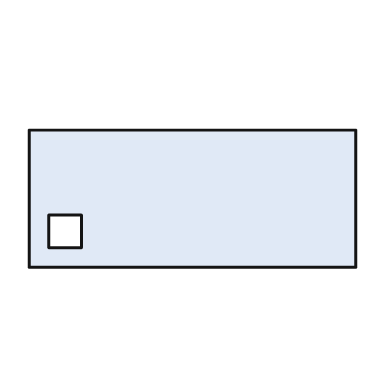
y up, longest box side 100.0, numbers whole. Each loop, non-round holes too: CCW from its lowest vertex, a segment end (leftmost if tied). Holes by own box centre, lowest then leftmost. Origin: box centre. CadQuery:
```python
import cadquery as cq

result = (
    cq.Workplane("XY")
    .moveTo(-50.0, -21.0)
    .lineTo(50.0, -21.0)
    .lineTo(50.0, 21.0)
    .lineTo(-50.0, 21.0)
    .close()
    .moveTo(-44.0, -15.0)
    .lineTo(-34.0, -15.0)
    .lineTo(-34.0, -5.0)
    .lineTo(-44.0, -5.0)
    .close()
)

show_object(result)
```